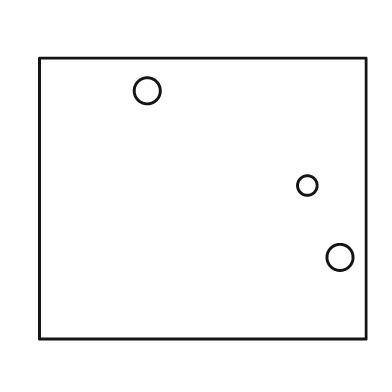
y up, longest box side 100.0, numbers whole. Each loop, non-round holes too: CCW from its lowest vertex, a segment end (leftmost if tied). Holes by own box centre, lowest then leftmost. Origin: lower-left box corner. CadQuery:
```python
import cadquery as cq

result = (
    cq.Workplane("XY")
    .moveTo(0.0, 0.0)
    .lineTo(100.0, 0.0)
    .lineTo(100.0, 86.0)
    .lineTo(0.0, 86.0)
    .close()
    .moveTo(92.0, 25.0)
    .circle(4.0)
    .moveTo(82.0, 47.0)
    .circle(3.0)
    .moveTo(33.0, 76.0)
    .circle(4.0)
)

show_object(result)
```